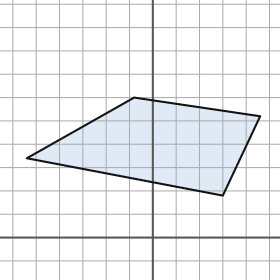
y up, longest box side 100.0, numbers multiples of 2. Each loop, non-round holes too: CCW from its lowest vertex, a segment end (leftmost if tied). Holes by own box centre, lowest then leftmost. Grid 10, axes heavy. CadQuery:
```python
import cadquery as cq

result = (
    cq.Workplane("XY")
    .moveTo(30.0, 18.0)
    .lineTo(46.0, 52.0)
    .lineTo(-8.0, 60.0)
    .lineTo(-54.0, 34.0)
    .close()
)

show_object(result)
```